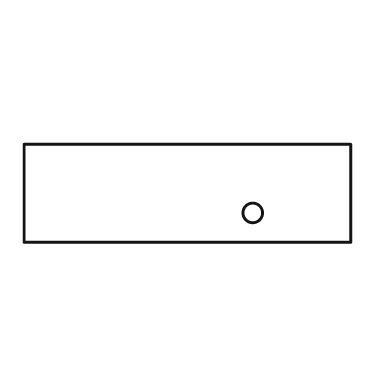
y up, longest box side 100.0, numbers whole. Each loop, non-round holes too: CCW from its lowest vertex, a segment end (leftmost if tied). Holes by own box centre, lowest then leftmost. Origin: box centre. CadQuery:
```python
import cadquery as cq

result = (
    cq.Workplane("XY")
    .moveTo(-50.0, -15.0)
    .lineTo(50.0, -15.0)
    .lineTo(50.0, 15.0)
    .lineTo(-50.0, 15.0)
    .close()
    .moveTo(20.0, -6.0)
    .circle(3.0)
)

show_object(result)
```